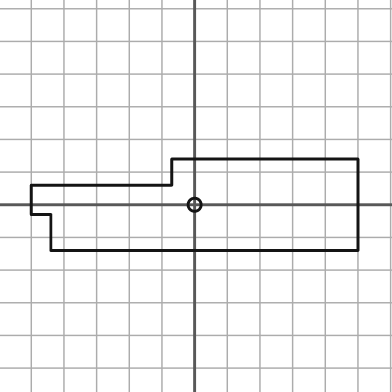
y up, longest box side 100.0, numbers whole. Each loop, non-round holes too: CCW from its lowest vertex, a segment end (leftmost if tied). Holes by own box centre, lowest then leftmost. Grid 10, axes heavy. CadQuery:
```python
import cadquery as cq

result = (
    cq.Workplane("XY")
    .moveTo(-44.0, -14.0)
    .lineTo(50.0, -14.0)
    .lineTo(50.0, 14.0)
    .lineTo(-7.0, 14.0)
    .lineTo(-7.0, 6.0)
    .lineTo(-50.0, 6.0)
    .lineTo(-50.0, -3.0)
    .lineTo(-44.0, -3.0)
    .close()
    .moveTo(0.0, 0.0)
    .circle(2.0)
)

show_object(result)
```